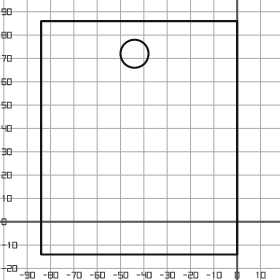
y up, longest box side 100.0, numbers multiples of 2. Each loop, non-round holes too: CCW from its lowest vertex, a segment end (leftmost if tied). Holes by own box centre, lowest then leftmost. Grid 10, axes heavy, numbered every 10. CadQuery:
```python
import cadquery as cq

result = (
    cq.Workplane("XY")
    .moveTo(-84.0, -14.0)
    .lineTo(0.0, -14.0)
    .lineTo(0.0, 86.0)
    .lineTo(-84.0, 86.0)
    .close()
    .moveTo(-44.0, 72.0)
    .circle(6.0)
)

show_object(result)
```